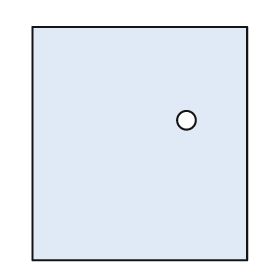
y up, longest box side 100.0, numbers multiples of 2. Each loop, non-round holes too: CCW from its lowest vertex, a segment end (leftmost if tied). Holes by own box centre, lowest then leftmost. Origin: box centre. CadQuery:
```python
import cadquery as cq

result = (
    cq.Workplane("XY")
    .moveTo(-46.0, -50.0)
    .lineTo(46.0, -50.0)
    .lineTo(46.0, 50.0)
    .lineTo(-46.0, 50.0)
    .close()
    .moveTo(20.0, 10.0)
    .circle(4.0)
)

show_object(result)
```